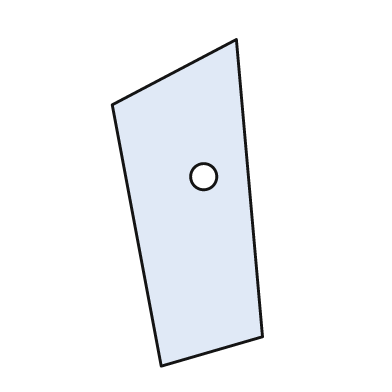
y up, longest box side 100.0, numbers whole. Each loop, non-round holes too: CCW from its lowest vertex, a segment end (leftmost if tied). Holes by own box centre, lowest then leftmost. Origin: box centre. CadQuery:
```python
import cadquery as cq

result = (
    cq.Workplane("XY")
    .moveTo(-8.0, -50.0)
    .lineTo(23.0, -41.0)
    .lineTo(15.0, 50.0)
    .lineTo(-23.0, 30.0)
    .close()
    .moveTo(5.0, 8.0)
    .circle(4.0)
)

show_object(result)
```